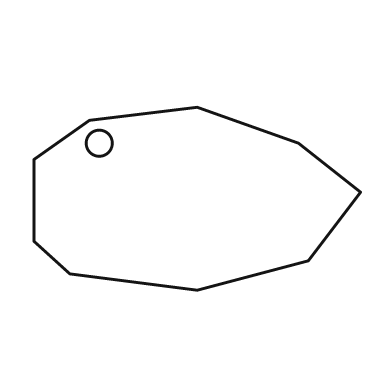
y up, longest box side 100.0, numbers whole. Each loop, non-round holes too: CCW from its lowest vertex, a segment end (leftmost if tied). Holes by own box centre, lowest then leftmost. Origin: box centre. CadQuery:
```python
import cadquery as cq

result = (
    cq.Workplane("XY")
    .moveTo(0.0, -28.0)
    .lineTo(34.0, -19.0)
    .lineTo(50.0, 2.0)
    .lineTo(31.0, 17.0)
    .lineTo(0.0, 28.0)
    .lineTo(-33.0, 24.0)
    .lineTo(-50.0, 12.0)
    .lineTo(-50.0, -13.0)
    .lineTo(-39.0, -23.0)
    .close()
    .moveTo(-30.0, 17.0)
    .circle(4.0)
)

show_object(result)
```